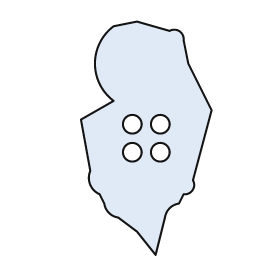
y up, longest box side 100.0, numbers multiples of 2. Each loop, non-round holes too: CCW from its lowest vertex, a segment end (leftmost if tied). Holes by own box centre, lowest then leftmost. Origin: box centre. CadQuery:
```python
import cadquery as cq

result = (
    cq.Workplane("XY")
    .moveTo(4.0, -50.0)
    .lineTo(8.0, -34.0)
    .threePointArc((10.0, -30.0), (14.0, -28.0))
    .lineTo(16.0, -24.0)
    .threePointArc((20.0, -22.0), (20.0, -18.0))
    .lineTo(28.0, 12.0)
    .lineTo(18.0, 32.0)
    .lineTo(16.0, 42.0)
    .threePointArc((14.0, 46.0), (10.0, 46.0))
    .lineTo(-4.0, 50.0)
    .lineTo(-14.0, 48.0)
    .threePointArc((-22.0, 32.0), (-14.0, 16.0))
    .lineTo(-28.0, 8.0)
    .lineTo(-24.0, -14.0)
    .threePointArc((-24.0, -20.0), (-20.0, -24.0))
    .lineTo(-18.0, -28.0)
    .threePointArc((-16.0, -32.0), (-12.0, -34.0))
    .lineTo(-4.0, -40.0)
    .close()
    .moveTo(-6.0, -6.0)
    .circle(4.0)
    .moveTo(6.0, -6.0)
    .circle(4.0)
    .moveTo(-6.0, 6.0)
    .circle(4.0)
    .moveTo(6.0, 6.0)
    .circle(4.0)
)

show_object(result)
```